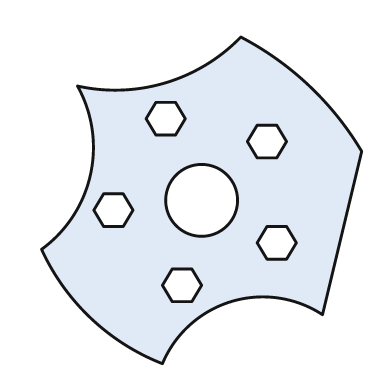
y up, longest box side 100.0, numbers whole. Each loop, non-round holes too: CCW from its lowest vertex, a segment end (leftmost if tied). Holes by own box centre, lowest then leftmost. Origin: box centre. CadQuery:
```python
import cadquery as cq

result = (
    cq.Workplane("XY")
    .moveTo(-12.0, -50.0)
    .threePointArc((9.0, -31.0), (37.0, -35.0))
    .lineTo(49.0, 15.0)
    .threePointArc((33.0, 35.0), (12.0, 50.0))
    .threePointArc((-11.0, 36.0), (-38.0, 35.0))
    .threePointArc((-34.0, 8.0), (-49.0, -15.0))
    .threePointArc((-34.0, -36.0), (-12.0, -50.0))
    .close()
    .moveTo(-9.0, -31.0)
    .lineTo(-3.0, -31.0)
    .lineTo(0.0, -26.0)
    .lineTo(-3.0, -21.0)
    .lineTo(-9.0, -21.0)
    .lineTo(-12.0, -26.0)
    .close()
    .moveTo(20.0, -18.0)
    .lineTo(26.0, -18.0)
    .lineTo(29.0, -13.0)
    .lineTo(26.0, -8.0)
    .lineTo(20.0, -8.0)
    .lineTo(17.0, -13.0)
    .close()
    .moveTo(-30.0, -8.0)
    .lineTo(-24.0, -8.0)
    .lineTo(-21.0, -3.0)
    .lineTo(-24.0, 2.0)
    .lineTo(-30.0, 2.0)
    .lineTo(-33.0, -3.0)
    .close()
    .moveTo(0.0, 0.0)
    .circle(11.0)
    .moveTo(17.0, 13.0)
    .lineTo(23.0, 13.0)
    .lineTo(26.0, 18.0)
    .lineTo(23.0, 23.0)
    .lineTo(17.0, 23.0)
    .lineTo(14.0, 18.0)
    .close()
    .moveTo(-14.0, 20.0)
    .lineTo(-8.0, 20.0)
    .lineTo(-5.0, 25.0)
    .lineTo(-8.0, 30.0)
    .lineTo(-14.0, 30.0)
    .lineTo(-17.0, 25.0)
    .close()
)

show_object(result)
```